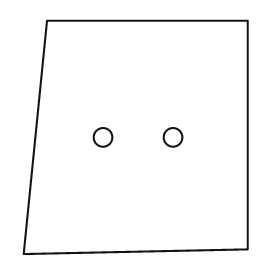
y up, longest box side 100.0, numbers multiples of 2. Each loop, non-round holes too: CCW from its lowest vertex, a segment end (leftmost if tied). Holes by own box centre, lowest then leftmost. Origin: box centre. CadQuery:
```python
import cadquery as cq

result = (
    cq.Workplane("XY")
    .moveTo(-48.0, -50.0)
    .lineTo(48.0, -48.0)
    .lineTo(48.0, 50.0)
    .lineTo(-38.0, 50.0)
    .close()
    .moveTo(-14.0, 0.0)
    .circle(4.0)
    .moveTo(16.0, 0.0)
    .circle(4.0)
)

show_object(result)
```